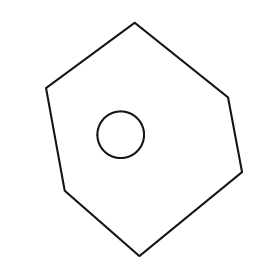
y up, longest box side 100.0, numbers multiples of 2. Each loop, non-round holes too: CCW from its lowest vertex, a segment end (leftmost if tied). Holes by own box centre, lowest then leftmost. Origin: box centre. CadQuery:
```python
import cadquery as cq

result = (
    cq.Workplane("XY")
    .moveTo(-2.0, -50.0)
    .lineTo(42.0, -14.0)
    .lineTo(36.0, 18.0)
    .lineTo(-4.0, 50.0)
    .lineTo(-42.0, 22.0)
    .lineTo(-34.0, -22.0)
    .close()
    .moveTo(-10.0, 2.0)
    .circle(10.0)
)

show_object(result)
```